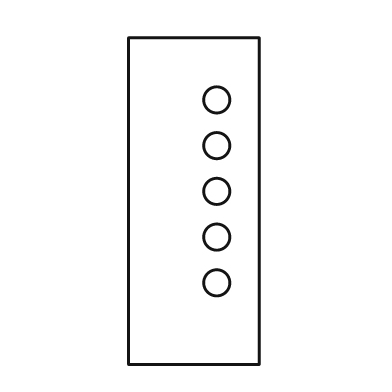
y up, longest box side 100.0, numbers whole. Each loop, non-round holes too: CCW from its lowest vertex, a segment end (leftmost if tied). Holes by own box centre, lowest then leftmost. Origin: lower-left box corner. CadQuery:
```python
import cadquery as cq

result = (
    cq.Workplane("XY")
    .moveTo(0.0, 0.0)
    .lineTo(40.0, 0.0)
    .lineTo(40.0, 100.0)
    .lineTo(0.0, 100.0)
    .close()
    .moveTo(27.0, 25.0)
    .circle(4.0)
    .moveTo(27.0, 39.0)
    .circle(4.0)
    .moveTo(27.0, 53.0)
    .circle(4.0)
    .moveTo(27.0, 67.0)
    .circle(4.0)
    .moveTo(27.0, 81.0)
    .circle(4.0)
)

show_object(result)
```